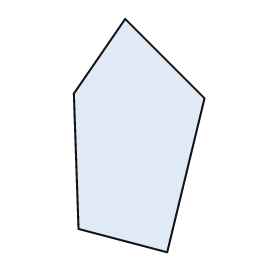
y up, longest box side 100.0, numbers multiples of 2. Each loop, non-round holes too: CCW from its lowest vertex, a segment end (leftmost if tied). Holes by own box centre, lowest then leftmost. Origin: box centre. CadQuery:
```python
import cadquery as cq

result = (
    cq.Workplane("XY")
    .moveTo(12.0, -50.0)
    .lineTo(28.0, 16.0)
    .lineTo(-6.0, 50.0)
    .lineTo(-28.0, 18.0)
    .lineTo(-26.0, -40.0)
    .close()
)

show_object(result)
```